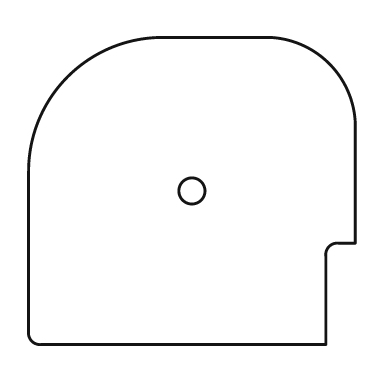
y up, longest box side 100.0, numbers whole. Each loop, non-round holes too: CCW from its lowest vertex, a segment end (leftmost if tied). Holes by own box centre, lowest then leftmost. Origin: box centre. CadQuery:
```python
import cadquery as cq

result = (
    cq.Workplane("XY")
    .moveTo(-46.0, -47.0)
    .lineTo(41.0, -47.0)
    .lineTo(41.0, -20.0)
    .threePointArc((42.0, -17.0), (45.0, -16.0))
    .lineTo(50.0, -16.0)
    .lineTo(50.0, 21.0)
    .threePointArc((42.0, 39.0), (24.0, 47.0))
    .lineTo(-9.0, 47.0)
    .threePointArc((-38.0, 35.0), (-50.0, 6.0))
    .lineTo(-50.0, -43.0)
    .threePointArc((-49.0, -46.0), (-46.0, -47.0))
    .close()
    .moveTo(0.0, 0.0)
    .circle(4.0)
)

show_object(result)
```